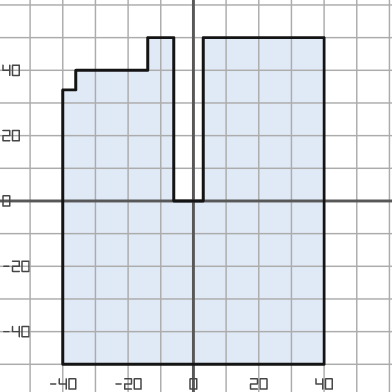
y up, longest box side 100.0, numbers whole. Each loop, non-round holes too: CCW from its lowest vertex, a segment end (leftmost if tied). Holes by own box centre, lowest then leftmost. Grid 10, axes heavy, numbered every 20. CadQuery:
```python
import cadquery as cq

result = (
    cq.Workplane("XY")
    .moveTo(-40.0, -50.0)
    .lineTo(40.0, -50.0)
    .lineTo(40.0, 50.0)
    .lineTo(3.0, 50.0)
    .lineTo(3.0, 0.0)
    .lineTo(-6.0, 0.0)
    .lineTo(-6.0, 50.0)
    .lineTo(-14.0, 50.0)
    .lineTo(-14.0, 40.0)
    .lineTo(-36.0, 40.0)
    .lineTo(-36.0, 34.0)
    .lineTo(-40.0, 34.0)
    .close()
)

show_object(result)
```